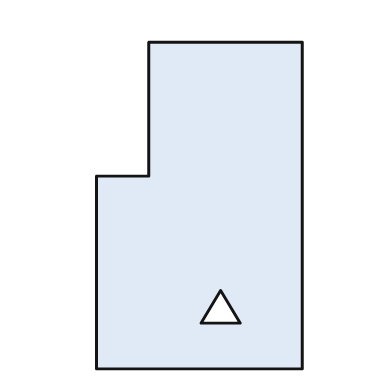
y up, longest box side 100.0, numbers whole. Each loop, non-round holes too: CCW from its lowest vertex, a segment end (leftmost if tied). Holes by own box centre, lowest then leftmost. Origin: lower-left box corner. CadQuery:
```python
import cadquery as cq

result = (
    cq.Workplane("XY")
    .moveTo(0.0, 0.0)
    .lineTo(63.0, 0.0)
    .lineTo(63.0, 100.0)
    .lineTo(16.0, 100.0)
    .lineTo(16.0, 59.0)
    .lineTo(0.0, 59.0)
    .close()
    .moveTo(32.0, 14.0)
    .lineTo(44.0, 14.0)
    .lineTo(38.0, 24.0)
    .close()
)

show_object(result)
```